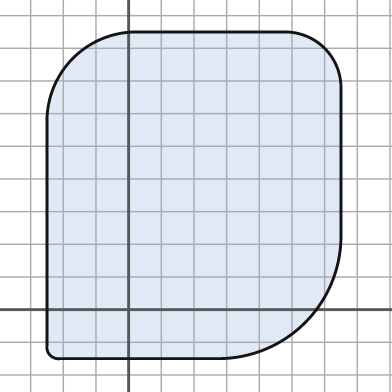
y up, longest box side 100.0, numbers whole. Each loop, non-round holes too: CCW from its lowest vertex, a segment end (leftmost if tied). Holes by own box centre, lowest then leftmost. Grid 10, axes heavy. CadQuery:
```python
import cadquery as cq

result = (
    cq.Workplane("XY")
    .moveTo(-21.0, -15.0)
    .lineTo(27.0, -15.0)
    .threePointArc((54.0, -4.0), (65.0, 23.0))
    .lineTo(65.0, 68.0)
    .threePointArc((60.0, 80.0), (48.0, 85.0))
    .lineTo(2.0, 85.0)
    .threePointArc((-17.0, 77.0), (-25.0, 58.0))
    .lineTo(-25.0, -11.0)
    .threePointArc((-24.0, -14.0), (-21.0, -15.0))
    .close()
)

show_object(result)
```